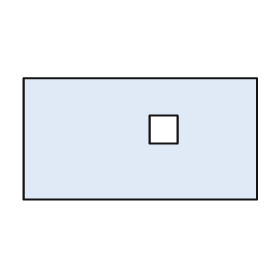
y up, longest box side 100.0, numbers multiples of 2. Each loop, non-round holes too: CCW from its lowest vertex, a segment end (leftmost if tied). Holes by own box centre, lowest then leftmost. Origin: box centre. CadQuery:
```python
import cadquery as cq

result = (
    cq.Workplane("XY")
    .moveTo(-50.0, -26.0)
    .lineTo(50.0, -26.0)
    .lineTo(50.0, 26.0)
    .lineTo(-50.0, 26.0)
    .close()
    .moveTo(4.0, -2.0)
    .lineTo(16.0, -2.0)
    .lineTo(16.0, 10.0)
    .lineTo(4.0, 10.0)
    .close()
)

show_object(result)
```